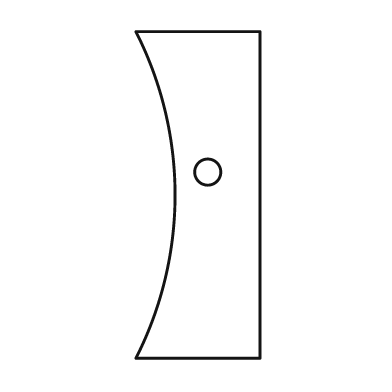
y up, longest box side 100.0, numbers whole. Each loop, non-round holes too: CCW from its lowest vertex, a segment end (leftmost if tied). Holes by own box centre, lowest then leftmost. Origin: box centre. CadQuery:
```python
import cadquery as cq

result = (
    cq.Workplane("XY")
    .moveTo(-19.0, -50.0)
    .lineTo(19.0, -50.0)
    .lineTo(19.0, 50.0)
    .lineTo(-19.0, 50.0)
    .threePointArc((-7.0, 0.0), (-19.0, -50.0))
    .close()
    .moveTo(3.0, 7.0)
    .circle(4.0)
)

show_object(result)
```